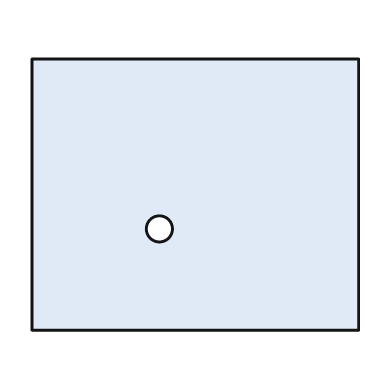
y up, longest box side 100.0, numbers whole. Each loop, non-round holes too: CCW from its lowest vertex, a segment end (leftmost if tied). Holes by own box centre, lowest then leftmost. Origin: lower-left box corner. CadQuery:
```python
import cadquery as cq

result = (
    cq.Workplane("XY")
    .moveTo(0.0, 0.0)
    .lineTo(100.0, 0.0)
    .lineTo(100.0, 83.0)
    .lineTo(0.0, 83.0)
    .close()
    .moveTo(39.0, 31.0)
    .circle(4.0)
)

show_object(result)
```